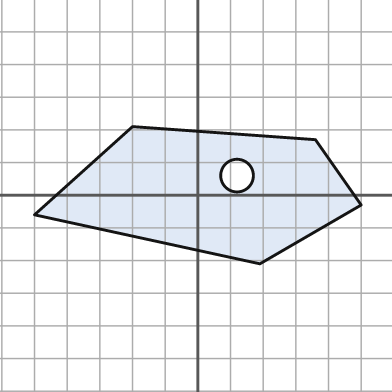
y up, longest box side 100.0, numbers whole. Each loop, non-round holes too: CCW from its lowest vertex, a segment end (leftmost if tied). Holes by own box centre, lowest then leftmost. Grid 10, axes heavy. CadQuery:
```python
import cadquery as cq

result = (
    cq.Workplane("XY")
    .moveTo(19.0, -21.0)
    .lineTo(50.0, -3.0)
    .lineTo(36.0, 17.0)
    .lineTo(-20.0, 21.0)
    .lineTo(-50.0, -6.0)
    .close()
    .moveTo(12.0, 6.0)
    .circle(5.0)
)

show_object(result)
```